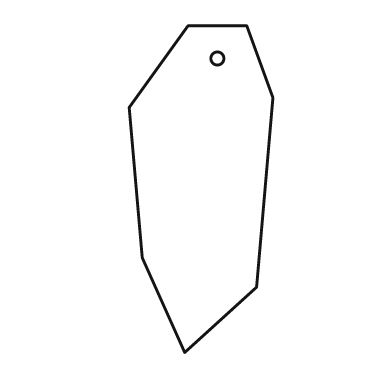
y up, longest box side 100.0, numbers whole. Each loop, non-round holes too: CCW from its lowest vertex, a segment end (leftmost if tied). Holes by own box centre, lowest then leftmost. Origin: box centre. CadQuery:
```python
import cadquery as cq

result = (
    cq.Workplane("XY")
    .moveTo(-5.0, -50.0)
    .lineTo(17.0, -30.0)
    .lineTo(22.0, 28.0)
    .lineTo(14.0, 50.0)
    .lineTo(-4.0, 50.0)
    .lineTo(-22.0, 25.0)
    .lineTo(-18.0, -21.0)
    .close()
    .moveTo(5.0, 40.0)
    .circle(2.0)
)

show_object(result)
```